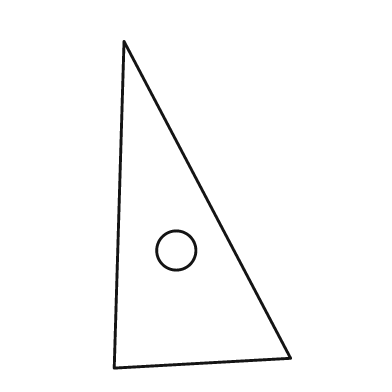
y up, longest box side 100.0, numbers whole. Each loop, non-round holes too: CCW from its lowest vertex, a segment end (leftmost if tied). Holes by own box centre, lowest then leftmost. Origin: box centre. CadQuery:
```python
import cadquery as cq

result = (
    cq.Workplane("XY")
    .moveTo(-27.0, -50.0)
    .lineTo(27.0, -47.0)
    .lineTo(-24.0, 50.0)
    .close()
    .moveTo(-8.0, -14.0)
    .circle(6.0)
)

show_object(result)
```